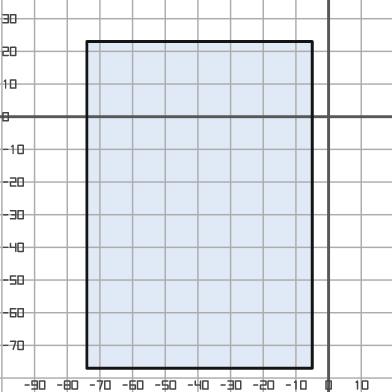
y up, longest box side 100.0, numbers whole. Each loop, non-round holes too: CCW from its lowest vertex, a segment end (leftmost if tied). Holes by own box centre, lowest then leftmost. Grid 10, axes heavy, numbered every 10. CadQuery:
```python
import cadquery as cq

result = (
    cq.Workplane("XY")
    .moveTo(-74.0, -77.0)
    .lineTo(-5.0, -77.0)
    .lineTo(-5.0, 23.0)
    .lineTo(-74.0, 23.0)
    .close()
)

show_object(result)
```